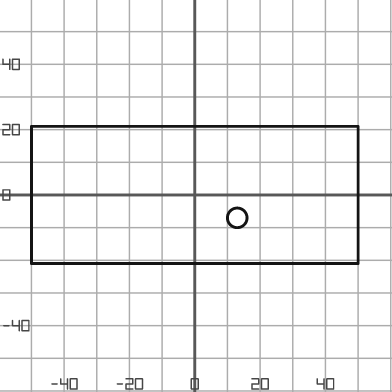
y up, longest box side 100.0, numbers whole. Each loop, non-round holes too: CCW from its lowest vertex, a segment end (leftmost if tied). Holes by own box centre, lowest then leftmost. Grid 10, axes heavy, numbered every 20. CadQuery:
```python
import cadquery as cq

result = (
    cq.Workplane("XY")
    .moveTo(-50.0, -21.0)
    .lineTo(50.0, -21.0)
    .lineTo(50.0, 21.0)
    .lineTo(-50.0, 21.0)
    .close()
    .moveTo(13.0, -7.0)
    .circle(3.0)
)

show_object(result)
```